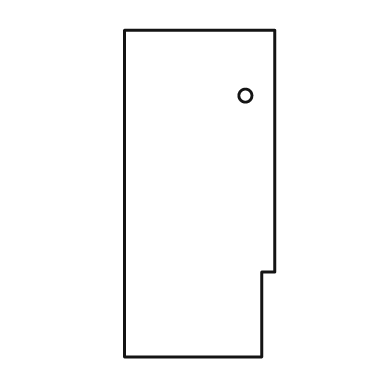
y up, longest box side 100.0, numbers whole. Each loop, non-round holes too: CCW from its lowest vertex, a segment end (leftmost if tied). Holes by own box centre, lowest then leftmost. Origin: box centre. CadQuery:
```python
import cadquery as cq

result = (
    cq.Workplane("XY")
    .moveTo(-23.0, -50.0)
    .lineTo(19.0, -50.0)
    .lineTo(19.0, -24.0)
    .lineTo(23.0, -24.0)
    .lineTo(23.0, 50.0)
    .lineTo(-23.0, 50.0)
    .close()
    .moveTo(14.0, 30.0)
    .circle(2.0)
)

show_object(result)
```